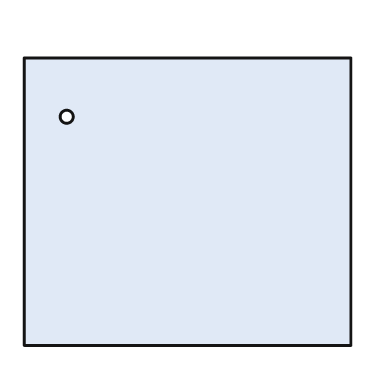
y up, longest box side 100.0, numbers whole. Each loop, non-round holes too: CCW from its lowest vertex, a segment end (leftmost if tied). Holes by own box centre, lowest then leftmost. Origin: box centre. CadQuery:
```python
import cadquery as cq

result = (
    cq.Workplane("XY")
    .moveTo(-50.0, -44.0)
    .lineTo(50.0, -44.0)
    .lineTo(50.0, 44.0)
    .lineTo(-50.0, 44.0)
    .close()
    .moveTo(-37.0, 26.0)
    .circle(2.0)
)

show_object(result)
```